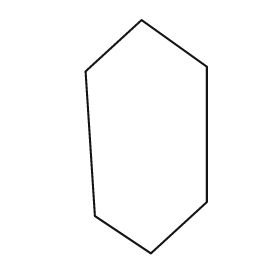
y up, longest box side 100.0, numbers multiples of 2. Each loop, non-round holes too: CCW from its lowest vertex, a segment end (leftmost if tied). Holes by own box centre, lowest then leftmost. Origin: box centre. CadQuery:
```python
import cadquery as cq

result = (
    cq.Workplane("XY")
    .moveTo(2.0, -50.0)
    .lineTo(26.0, -28.0)
    .lineTo(26.0, 30.0)
    .lineTo(-2.0, 50.0)
    .lineTo(-26.0, 28.0)
    .lineTo(-22.0, -34.0)
    .close()
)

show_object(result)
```